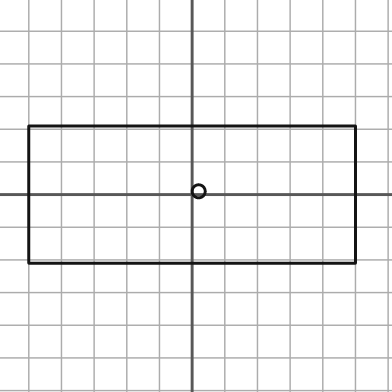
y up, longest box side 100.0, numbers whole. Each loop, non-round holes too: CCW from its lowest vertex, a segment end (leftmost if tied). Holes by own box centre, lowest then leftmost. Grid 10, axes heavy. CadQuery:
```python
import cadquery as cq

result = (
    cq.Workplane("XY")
    .moveTo(-50.0, -21.0)
    .lineTo(50.0, -21.0)
    .lineTo(50.0, 21.0)
    .lineTo(-50.0, 21.0)
    .close()
    .moveTo(2.0, 1.0)
    .circle(2.0)
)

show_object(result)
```